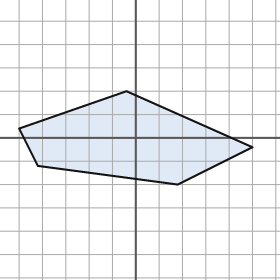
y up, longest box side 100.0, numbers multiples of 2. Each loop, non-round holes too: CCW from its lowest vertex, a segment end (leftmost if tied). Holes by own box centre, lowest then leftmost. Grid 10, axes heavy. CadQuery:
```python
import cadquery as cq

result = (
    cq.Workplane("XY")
    .moveTo(18.0, -20.0)
    .lineTo(50.0, -4.0)
    .lineTo(-4.0, 20.0)
    .lineTo(-50.0, 4.0)
    .lineTo(-42.0, -12.0)
    .close()
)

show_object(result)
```